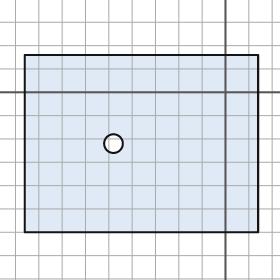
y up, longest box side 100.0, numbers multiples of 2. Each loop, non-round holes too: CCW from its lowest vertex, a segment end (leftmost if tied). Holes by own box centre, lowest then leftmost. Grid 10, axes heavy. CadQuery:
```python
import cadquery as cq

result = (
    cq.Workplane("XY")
    .moveTo(-86.0, -60.0)
    .lineTo(14.0, -60.0)
    .lineTo(14.0, 16.0)
    .lineTo(-86.0, 16.0)
    .close()
    .moveTo(-48.0, -22.0)
    .circle(4.0)
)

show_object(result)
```